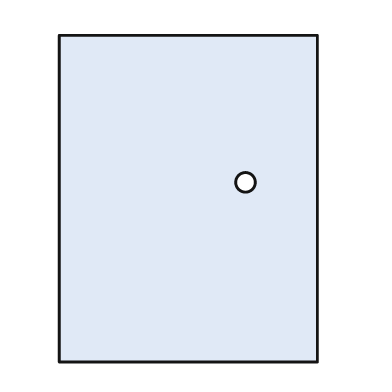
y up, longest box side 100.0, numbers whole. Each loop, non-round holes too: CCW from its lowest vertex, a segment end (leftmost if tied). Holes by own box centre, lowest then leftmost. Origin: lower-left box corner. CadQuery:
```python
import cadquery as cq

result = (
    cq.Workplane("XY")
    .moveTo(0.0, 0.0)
    .lineTo(79.0, 0.0)
    .lineTo(79.0, 100.0)
    .lineTo(0.0, 100.0)
    .close()
    .moveTo(57.0, 55.0)
    .circle(3.0)
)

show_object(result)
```